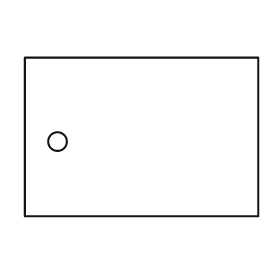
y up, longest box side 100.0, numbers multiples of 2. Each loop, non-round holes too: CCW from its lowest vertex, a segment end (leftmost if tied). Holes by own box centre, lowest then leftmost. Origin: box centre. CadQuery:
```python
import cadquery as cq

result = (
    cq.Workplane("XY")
    .moveTo(-50.0, -34.0)
    .lineTo(50.0, -34.0)
    .lineTo(50.0, 34.0)
    .lineTo(-50.0, 34.0)
    .close()
    .moveTo(-36.0, -2.0)
    .circle(4.0)
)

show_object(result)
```